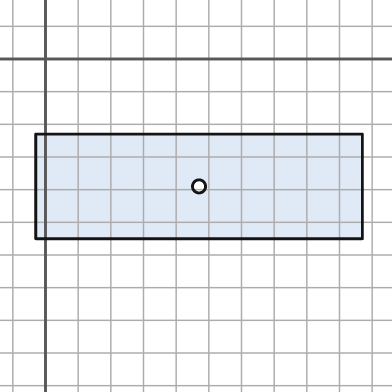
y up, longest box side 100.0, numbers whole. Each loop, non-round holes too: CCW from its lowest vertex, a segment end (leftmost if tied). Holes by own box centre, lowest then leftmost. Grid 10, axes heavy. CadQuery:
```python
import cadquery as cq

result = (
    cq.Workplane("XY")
    .moveTo(-3.0, -55.0)
    .lineTo(97.0, -55.0)
    .lineTo(97.0, -23.0)
    .lineTo(-3.0, -23.0)
    .close()
    .moveTo(47.0, -39.0)
    .circle(2.0)
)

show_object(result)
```